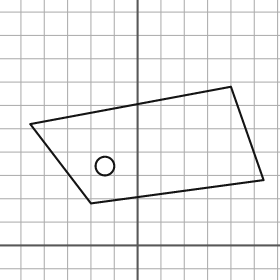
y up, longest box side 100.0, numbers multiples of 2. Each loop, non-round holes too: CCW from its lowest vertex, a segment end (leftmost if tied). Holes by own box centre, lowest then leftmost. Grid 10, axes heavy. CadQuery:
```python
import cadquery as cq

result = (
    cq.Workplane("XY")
    .moveTo(-20.0, 18.0)
    .lineTo(54.0, 28.0)
    .lineTo(40.0, 68.0)
    .lineTo(-46.0, 52.0)
    .close()
    .moveTo(-14.0, 34.0)
    .circle(4.0)
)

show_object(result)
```